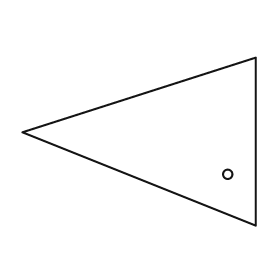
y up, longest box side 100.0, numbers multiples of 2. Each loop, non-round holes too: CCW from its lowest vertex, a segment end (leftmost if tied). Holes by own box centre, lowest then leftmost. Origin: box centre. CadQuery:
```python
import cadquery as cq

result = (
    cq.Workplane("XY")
    .moveTo(50.0, -36.0)
    .lineTo(50.0, 36.0)
    .lineTo(-50.0, 4.0)
    .close()
    .moveTo(38.0, -14.0)
    .circle(2.0)
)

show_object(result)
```